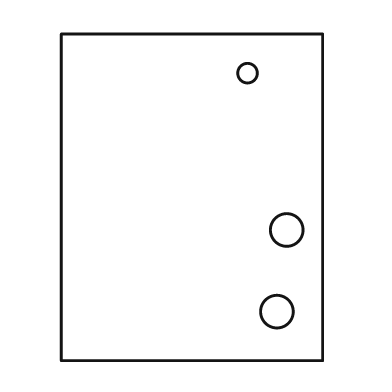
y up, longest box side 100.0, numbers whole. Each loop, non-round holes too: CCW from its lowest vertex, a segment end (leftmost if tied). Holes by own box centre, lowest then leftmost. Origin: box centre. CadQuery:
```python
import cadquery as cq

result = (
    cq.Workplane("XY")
    .moveTo(-40.0, -50.0)
    .lineTo(40.0, -50.0)
    .lineTo(40.0, 50.0)
    .lineTo(-40.0, 50.0)
    .close()
    .moveTo(26.0, -35.0)
    .circle(5.0)
    .moveTo(29.0, -10.0)
    .circle(5.0)
    .moveTo(17.0, 38.0)
    .circle(3.0)
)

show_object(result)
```